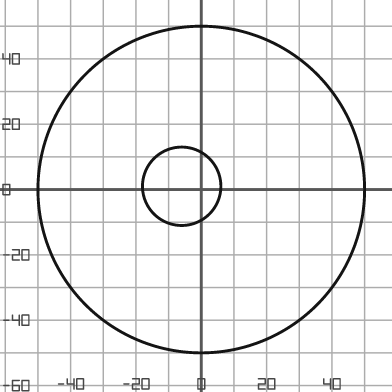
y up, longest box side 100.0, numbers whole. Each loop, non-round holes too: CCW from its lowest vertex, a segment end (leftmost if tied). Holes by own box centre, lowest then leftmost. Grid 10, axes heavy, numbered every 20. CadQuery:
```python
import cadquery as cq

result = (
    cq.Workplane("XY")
    .moveTo(0.0, 0.0)
    .circle(50.0)
    .moveTo(-6.0, 1.0)
    .circle(12.0)
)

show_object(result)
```